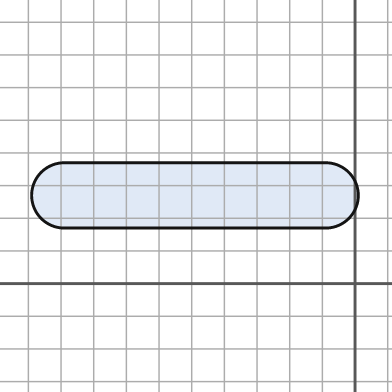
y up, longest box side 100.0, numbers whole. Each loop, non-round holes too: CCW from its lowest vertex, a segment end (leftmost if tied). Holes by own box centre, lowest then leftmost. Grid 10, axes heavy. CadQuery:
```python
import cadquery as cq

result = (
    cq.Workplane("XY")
    .moveTo(-89.0, 17.0)
    .lineTo(-9.0, 17.0)
    .threePointArc((1.0, 27.0), (-9.0, 37.0))
    .lineTo(-89.0, 37.0)
    .threePointArc((-99.0, 27.0), (-89.0, 17.0))
    .close()
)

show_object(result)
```